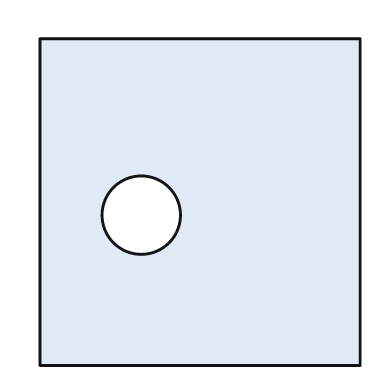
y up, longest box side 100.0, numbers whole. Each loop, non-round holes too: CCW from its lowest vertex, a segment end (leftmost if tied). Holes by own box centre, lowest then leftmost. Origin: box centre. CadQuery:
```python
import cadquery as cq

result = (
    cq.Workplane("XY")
    .moveTo(-49.0, -50.0)
    .lineTo(49.0, -50.0)
    .lineTo(49.0, 50.0)
    .lineTo(-49.0, 50.0)
    .close()
    .moveTo(-18.0, -4.0)
    .circle(12.0)
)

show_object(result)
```